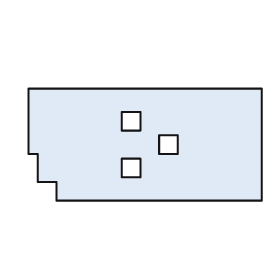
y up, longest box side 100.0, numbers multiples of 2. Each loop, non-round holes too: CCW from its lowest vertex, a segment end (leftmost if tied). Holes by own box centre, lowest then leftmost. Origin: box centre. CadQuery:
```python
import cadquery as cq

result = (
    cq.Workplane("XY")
    .moveTo(-38.0, -24.0)
    .lineTo(50.0, -24.0)
    .lineTo(50.0, 24.0)
    .lineTo(-50.0, 24.0)
    .lineTo(-50.0, -4.0)
    .lineTo(-46.0, -4.0)
    .lineTo(-46.0, -16.0)
    .lineTo(-38.0, -16.0)
    .close()
    .moveTo(-10.0, -14.0)
    .lineTo(-2.0, -14.0)
    .lineTo(-2.0, -6.0)
    .lineTo(-10.0, -6.0)
    .close()
    .moveTo(6.0, -4.0)
    .lineTo(14.0, -4.0)
    .lineTo(14.0, 4.0)
    .lineTo(6.0, 4.0)
    .close()
    .moveTo(-10.0, 6.0)
    .lineTo(-2.0, 6.0)
    .lineTo(-2.0, 14.0)
    .lineTo(-10.0, 14.0)
    .close()
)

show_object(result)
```